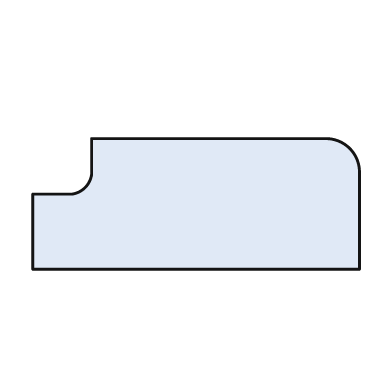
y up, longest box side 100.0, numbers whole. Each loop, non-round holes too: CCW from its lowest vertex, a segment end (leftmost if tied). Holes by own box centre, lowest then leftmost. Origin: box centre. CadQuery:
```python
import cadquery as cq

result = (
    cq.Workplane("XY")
    .moveTo(-50.0, -20.0)
    .lineTo(50.0, -20.0)
    .lineTo(50.0, 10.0)
    .threePointArc((47.0, 17.0), (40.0, 20.0))
    .lineTo(-32.0, 20.0)
    .lineTo(-32.0, 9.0)
    .threePointArc((-34.0, 5.0), (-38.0, 3.0))
    .lineTo(-50.0, 3.0)
    .close()
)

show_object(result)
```